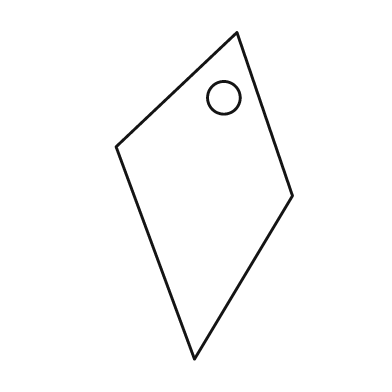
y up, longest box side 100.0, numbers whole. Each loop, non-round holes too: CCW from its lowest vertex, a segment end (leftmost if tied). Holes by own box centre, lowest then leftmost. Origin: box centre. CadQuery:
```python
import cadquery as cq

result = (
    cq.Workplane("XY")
    .moveTo(-3.0, -50.0)
    .lineTo(27.0, 0.0)
    .lineTo(10.0, 50.0)
    .lineTo(-27.0, 15.0)
    .close()
    .moveTo(6.0, 30.0)
    .circle(5.0)
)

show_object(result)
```